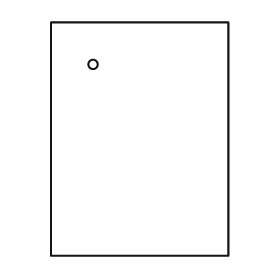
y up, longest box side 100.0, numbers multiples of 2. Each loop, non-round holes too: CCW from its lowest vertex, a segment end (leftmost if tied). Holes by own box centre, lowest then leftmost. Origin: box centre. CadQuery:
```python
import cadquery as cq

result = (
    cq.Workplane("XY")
    .moveTo(-38.0, -50.0)
    .lineTo(38.0, -50.0)
    .lineTo(38.0, 50.0)
    .lineTo(-38.0, 50.0)
    .close()
    .moveTo(-20.0, 32.0)
    .circle(2.0)
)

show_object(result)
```